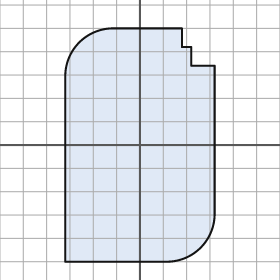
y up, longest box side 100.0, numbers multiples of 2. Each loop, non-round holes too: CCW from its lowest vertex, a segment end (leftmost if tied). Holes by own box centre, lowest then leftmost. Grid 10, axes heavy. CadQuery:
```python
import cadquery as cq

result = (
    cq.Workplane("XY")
    .moveTo(-32.0, -50.0)
    .lineTo(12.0, -50.0)
    .threePointArc((26.0, -44.0), (32.0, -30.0))
    .lineTo(32.0, 34.0)
    .lineTo(22.0, 34.0)
    .lineTo(22.0, 42.0)
    .lineTo(18.0, 42.0)
    .lineTo(18.0, 50.0)
    .lineTo(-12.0, 50.0)
    .threePointArc((-26.0, 44.0), (-32.0, 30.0))
    .close()
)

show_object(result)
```